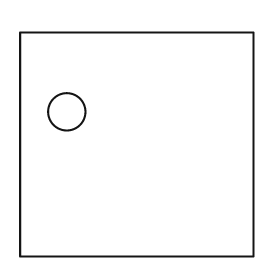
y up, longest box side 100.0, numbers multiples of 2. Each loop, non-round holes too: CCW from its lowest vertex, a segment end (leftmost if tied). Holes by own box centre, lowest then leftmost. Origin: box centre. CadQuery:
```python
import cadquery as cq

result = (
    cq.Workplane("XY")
    .moveTo(-50.0, -48.0)
    .lineTo(50.0, -48.0)
    .lineTo(50.0, 48.0)
    .lineTo(-50.0, 48.0)
    .close()
    .moveTo(-30.0, 14.0)
    .circle(8.0)
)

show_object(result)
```